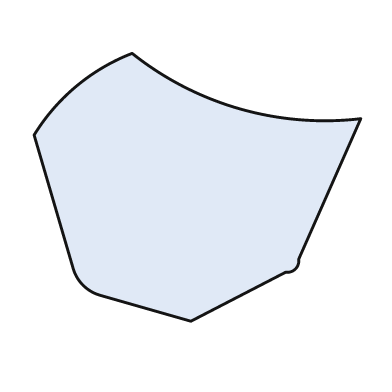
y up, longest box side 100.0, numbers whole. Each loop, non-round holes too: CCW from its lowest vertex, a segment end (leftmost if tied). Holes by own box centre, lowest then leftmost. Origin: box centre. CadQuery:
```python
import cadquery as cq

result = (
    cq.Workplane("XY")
    .moveTo(-2.0, -41.0)
    .lineTo(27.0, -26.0)
    .threePointArc((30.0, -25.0), (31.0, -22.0))
    .lineTo(50.0, 21.0)
    .threePointArc((13.0, 24.0), (-20.0, 41.0))
    .threePointArc((-37.0, 31.0), (-50.0, 16.0))
    .lineTo(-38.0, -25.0)
    .threePointArc((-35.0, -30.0), (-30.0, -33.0))
    .close()
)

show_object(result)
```